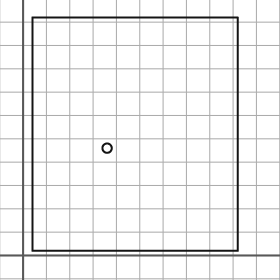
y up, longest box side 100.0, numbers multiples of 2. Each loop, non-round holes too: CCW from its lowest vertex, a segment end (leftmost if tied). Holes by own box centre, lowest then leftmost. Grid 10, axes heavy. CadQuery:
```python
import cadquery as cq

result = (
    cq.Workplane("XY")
    .moveTo(4.0, 2.0)
    .lineTo(92.0, 2.0)
    .lineTo(92.0, 102.0)
    .lineTo(4.0, 102.0)
    .close()
    .moveTo(36.0, 46.0)
    .circle(2.0)
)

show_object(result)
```